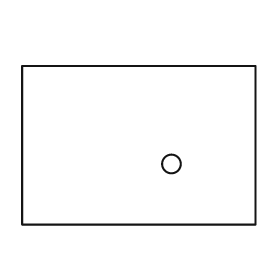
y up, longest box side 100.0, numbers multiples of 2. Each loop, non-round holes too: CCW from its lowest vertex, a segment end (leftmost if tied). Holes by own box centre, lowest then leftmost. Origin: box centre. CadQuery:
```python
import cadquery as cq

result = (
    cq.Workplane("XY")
    .moveTo(-50.0, -34.0)
    .lineTo(50.0, -34.0)
    .lineTo(50.0, 34.0)
    .lineTo(-50.0, 34.0)
    .close()
    .moveTo(14.0, -8.0)
    .circle(4.0)
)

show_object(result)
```